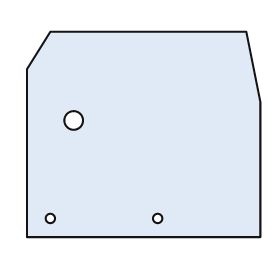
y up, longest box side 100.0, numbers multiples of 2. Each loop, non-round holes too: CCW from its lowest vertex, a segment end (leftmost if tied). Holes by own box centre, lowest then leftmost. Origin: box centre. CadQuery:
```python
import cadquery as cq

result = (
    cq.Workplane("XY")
    .moveTo(-50.0, -44.0)
    .lineTo(50.0, -44.0)
    .lineTo(50.0, 14.0)
    .lineTo(44.0, 44.0)
    .lineTo(-40.0, 44.0)
    .lineTo(-50.0, 28.0)
    .close()
    .moveTo(-40.0, -36.0)
    .circle(2.0)
    .moveTo(6.0, -36.0)
    .circle(2.0)
    .moveTo(-30.0, 6.0)
    .circle(4.0)
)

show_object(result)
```